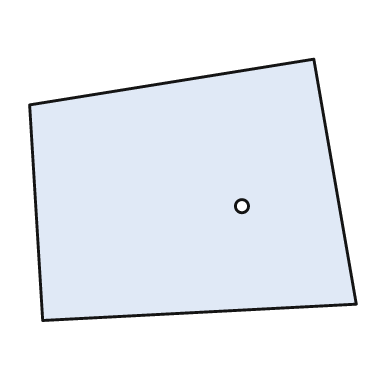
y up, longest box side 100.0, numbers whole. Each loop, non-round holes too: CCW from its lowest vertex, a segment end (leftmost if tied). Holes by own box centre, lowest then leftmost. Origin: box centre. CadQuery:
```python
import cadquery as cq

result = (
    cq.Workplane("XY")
    .moveTo(-46.0, -40.0)
    .lineTo(50.0, -35.0)
    .lineTo(37.0, 40.0)
    .lineTo(-50.0, 26.0)
    .close()
    .moveTo(15.0, -5.0)
    .circle(2.0)
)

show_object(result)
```